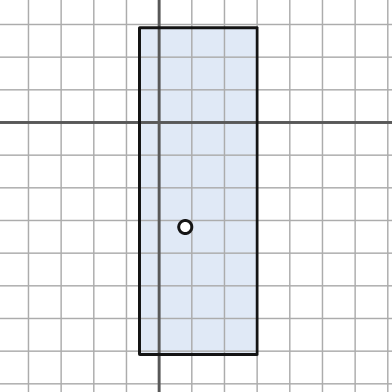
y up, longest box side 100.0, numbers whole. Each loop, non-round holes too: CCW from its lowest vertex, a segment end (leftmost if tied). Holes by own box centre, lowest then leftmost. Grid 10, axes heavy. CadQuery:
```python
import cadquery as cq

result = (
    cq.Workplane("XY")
    .moveTo(-6.0, -71.0)
    .lineTo(30.0, -71.0)
    .lineTo(30.0, 29.0)
    .lineTo(-6.0, 29.0)
    .close()
    .moveTo(8.0, -32.0)
    .circle(2.0)
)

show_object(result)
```